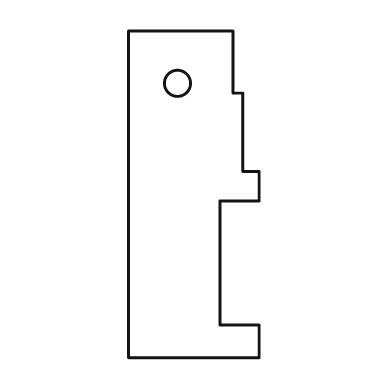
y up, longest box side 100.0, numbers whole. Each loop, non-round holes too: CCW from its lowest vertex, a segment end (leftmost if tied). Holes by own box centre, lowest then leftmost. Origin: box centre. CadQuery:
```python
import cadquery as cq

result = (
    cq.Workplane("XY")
    .moveTo(-20.0, -50.0)
    .lineTo(20.0, -50.0)
    .lineTo(20.0, -40.0)
    .lineTo(8.0, -40.0)
    .lineTo(8.0, -2.0)
    .lineTo(20.0, -2.0)
    .lineTo(20.0, 7.0)
    .lineTo(15.0, 7.0)
    .lineTo(15.0, 31.0)
    .lineTo(12.0, 31.0)
    .lineTo(12.0, 50.0)
    .lineTo(-20.0, 50.0)
    .close()
    .moveTo(-5.0, 34.0)
    .circle(4.0)
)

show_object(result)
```